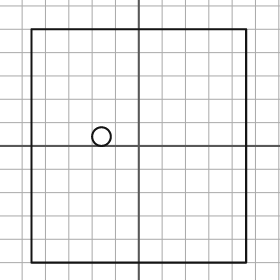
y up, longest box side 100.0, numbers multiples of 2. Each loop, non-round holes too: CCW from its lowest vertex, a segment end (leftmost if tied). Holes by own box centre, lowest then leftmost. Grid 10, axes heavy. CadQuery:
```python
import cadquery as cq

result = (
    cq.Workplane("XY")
    .moveTo(-46.0, -50.0)
    .lineTo(46.0, -50.0)
    .lineTo(46.0, 50.0)
    .lineTo(-46.0, 50.0)
    .close()
    .moveTo(-16.0, 4.0)
    .circle(4.0)
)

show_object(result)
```